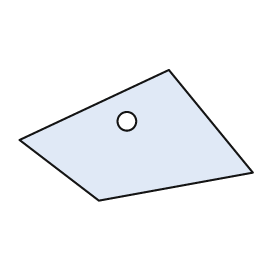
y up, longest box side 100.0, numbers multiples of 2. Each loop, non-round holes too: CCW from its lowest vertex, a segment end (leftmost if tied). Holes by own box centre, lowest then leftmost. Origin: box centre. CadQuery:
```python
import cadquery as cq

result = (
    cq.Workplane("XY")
    .moveTo(-16.0, -28.0)
    .lineTo(50.0, -16.0)
    .lineTo(14.0, 28.0)
    .lineTo(-50.0, -2.0)
    .close()
    .moveTo(-4.0, 6.0)
    .circle(4.0)
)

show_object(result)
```